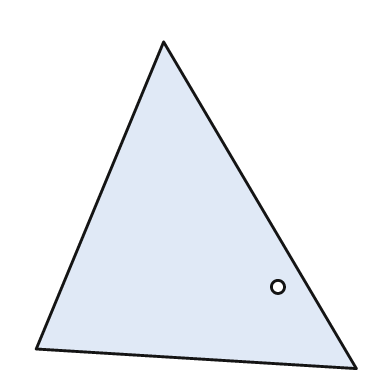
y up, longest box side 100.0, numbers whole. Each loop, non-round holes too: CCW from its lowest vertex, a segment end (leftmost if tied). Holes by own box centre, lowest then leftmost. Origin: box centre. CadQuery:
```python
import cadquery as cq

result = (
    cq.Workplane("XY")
    .moveTo(49.0, -50.0)
    .lineTo(-10.0, 50.0)
    .lineTo(-49.0, -44.0)
    .close()
    .moveTo(25.0, -25.0)
    .circle(2.0)
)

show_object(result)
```